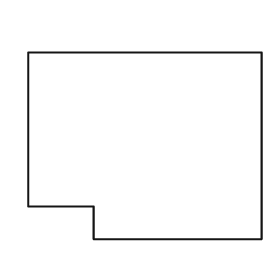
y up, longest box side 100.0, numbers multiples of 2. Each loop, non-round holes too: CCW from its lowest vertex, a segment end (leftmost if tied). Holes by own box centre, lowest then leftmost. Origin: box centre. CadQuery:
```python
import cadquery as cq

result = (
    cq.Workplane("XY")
    .moveTo(-22.0, -40.0)
    .lineTo(50.0, -40.0)
    .lineTo(50.0, 40.0)
    .lineTo(-50.0, 40.0)
    .lineTo(-50.0, -26.0)
    .lineTo(-22.0, -26.0)
    .close()
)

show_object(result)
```